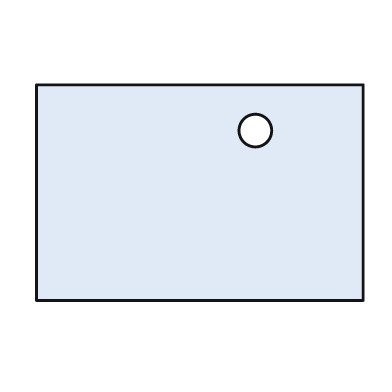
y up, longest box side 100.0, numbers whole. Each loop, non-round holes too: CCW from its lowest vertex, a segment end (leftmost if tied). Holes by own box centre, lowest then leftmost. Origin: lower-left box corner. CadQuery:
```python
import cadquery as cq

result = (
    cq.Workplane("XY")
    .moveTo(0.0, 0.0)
    .lineTo(100.0, 0.0)
    .lineTo(100.0, 66.0)
    .lineTo(0.0, 66.0)
    .close()
    .moveTo(67.0, 52.0)
    .circle(5.0)
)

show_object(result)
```